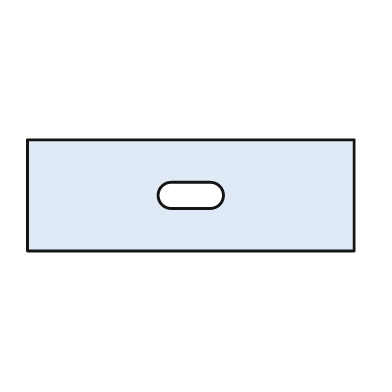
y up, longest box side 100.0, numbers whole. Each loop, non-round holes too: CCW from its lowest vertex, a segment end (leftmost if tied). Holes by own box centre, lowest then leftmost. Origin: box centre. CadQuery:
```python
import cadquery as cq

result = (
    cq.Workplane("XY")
    .moveTo(-50.0, -17.0)
    .lineTo(50.0, -17.0)
    .lineTo(50.0, 17.0)
    .lineTo(-50.0, 17.0)
    .close()
    .moveTo(-6.0, -4.0)
    .lineTo(6.0, -4.0)
    .threePointArc((10.0, 0.0), (6.0, 4.0))
    .lineTo(-6.0, 4.0)
    .threePointArc((-10.0, 0.0), (-6.0, -4.0))
    .close()
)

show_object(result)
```